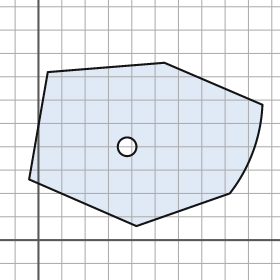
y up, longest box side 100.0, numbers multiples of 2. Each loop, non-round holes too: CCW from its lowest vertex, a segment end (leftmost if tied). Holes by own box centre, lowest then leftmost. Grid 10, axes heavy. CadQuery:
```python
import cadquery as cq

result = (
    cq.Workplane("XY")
    .moveTo(42.0, 6.0)
    .lineTo(82.0, 20.0)
    .threePointArc((92.0, 38.0), (96.0, 58.0))
    .lineTo(54.0, 76.0)
    .lineTo(4.0, 72.0)
    .lineTo(-4.0, 26.0)
    .close()
    .moveTo(38.0, 40.0)
    .circle(4.0)
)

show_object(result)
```